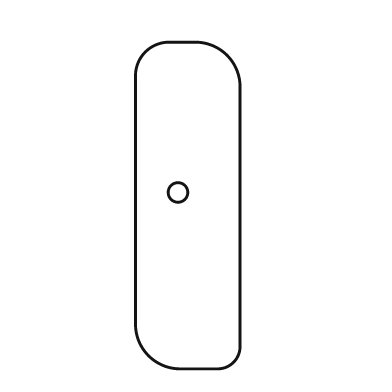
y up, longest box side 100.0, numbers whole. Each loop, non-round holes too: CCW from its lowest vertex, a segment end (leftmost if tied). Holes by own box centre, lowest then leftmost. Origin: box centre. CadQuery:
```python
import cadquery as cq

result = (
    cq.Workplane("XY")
    .moveTo(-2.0, -50.0)
    .lineTo(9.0, -50.0)
    .threePointArc((14.0, -48.0), (16.0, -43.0))
    .lineTo(16.0, 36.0)
    .threePointArc((12.0, 46.0), (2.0, 50.0))
    .lineTo(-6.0, 50.0)
    .threePointArc((-13.0, 47.0), (-16.0, 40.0))
    .lineTo(-16.0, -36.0)
    .threePointArc((-12.0, -46.0), (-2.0, -50.0))
    .close()
    .moveTo(-3.0, 4.0)
    .circle(3.0)
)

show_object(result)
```